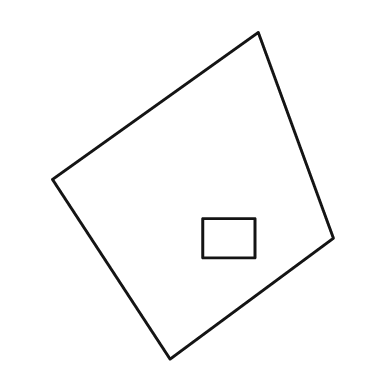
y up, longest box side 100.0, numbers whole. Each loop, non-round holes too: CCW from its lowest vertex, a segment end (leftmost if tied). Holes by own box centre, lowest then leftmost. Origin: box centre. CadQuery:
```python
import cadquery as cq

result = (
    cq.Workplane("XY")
    .moveTo(-7.0, -50.0)
    .lineTo(43.0, -13.0)
    .lineTo(20.0, 50.0)
    .lineTo(-43.0, 5.0)
    .close()
    .moveTo(3.0, -19.0)
    .lineTo(19.0, -19.0)
    .lineTo(19.0, -7.0)
    .lineTo(3.0, -7.0)
    .close()
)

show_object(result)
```